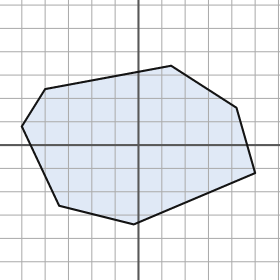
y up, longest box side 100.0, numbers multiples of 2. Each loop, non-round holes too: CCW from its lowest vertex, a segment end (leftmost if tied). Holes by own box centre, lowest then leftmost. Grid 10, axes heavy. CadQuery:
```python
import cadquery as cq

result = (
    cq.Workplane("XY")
    .moveTo(-2.0, -34.0)
    .lineTo(50.0, -12.0)
    .lineTo(42.0, 16.0)
    .lineTo(14.0, 34.0)
    .lineTo(-40.0, 24.0)
    .lineTo(-50.0, 8.0)
    .lineTo(-34.0, -26.0)
    .close()
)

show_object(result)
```